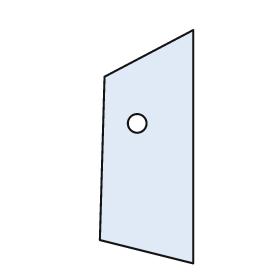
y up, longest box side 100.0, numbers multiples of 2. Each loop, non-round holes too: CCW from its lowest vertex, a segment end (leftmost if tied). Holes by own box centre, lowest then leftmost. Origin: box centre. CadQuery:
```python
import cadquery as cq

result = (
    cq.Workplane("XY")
    .moveTo(20.0, -50.0)
    .lineTo(20.0, 50.0)
    .lineTo(-18.0, 30.0)
    .lineTo(-20.0, -40.0)
    .close()
    .moveTo(-4.0, 10.0)
    .circle(4.0)
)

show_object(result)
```